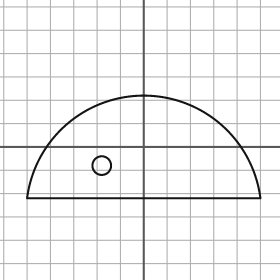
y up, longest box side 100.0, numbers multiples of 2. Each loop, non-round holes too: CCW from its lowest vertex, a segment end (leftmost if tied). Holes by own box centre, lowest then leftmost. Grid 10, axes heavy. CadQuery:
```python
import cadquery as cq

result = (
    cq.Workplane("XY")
    .moveTo(-50.0, -22.0)
    .lineTo(50.0, -22.0)
    .threePointArc((0.0, 22.0), (-50.0, -22.0))
    .close()
    .moveTo(-18.0, -8.0)
    .circle(4.0)
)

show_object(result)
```